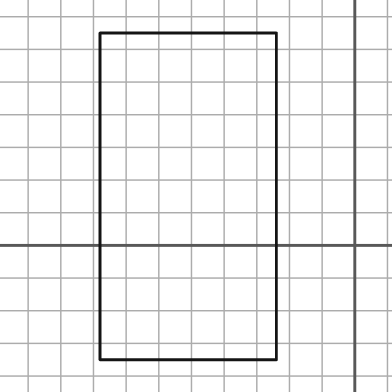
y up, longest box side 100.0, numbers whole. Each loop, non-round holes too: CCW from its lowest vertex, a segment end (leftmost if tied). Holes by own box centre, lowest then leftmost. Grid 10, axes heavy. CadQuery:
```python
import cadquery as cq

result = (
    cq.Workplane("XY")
    .moveTo(-78.0, -35.0)
    .lineTo(-24.0, -35.0)
    .lineTo(-24.0, 65.0)
    .lineTo(-78.0, 65.0)
    .close()
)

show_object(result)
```